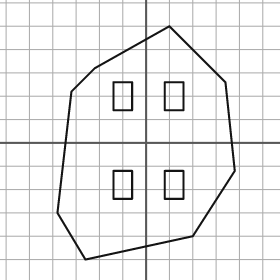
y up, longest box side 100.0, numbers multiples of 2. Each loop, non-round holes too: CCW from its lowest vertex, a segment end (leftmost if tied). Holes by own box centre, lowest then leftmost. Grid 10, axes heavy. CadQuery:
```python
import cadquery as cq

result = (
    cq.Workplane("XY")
    .moveTo(-26.0, -50.0)
    .lineTo(20.0, -40.0)
    .lineTo(38.0, -12.0)
    .lineTo(34.0, 26.0)
    .lineTo(10.0, 50.0)
    .lineTo(-22.0, 32.0)
    .lineTo(-32.0, 22.0)
    .lineTo(-38.0, -30.0)
    .close()
    .moveTo(-14.0, -24.0)
    .lineTo(-6.0, -24.0)
    .lineTo(-6.0, -12.0)
    .lineTo(-14.0, -12.0)
    .close()
    .moveTo(8.0, -24.0)
    .lineTo(16.0, -24.0)
    .lineTo(16.0, -12.0)
    .lineTo(8.0, -12.0)
    .close()
    .moveTo(-14.0, 14.0)
    .lineTo(-6.0, 14.0)
    .lineTo(-6.0, 26.0)
    .lineTo(-14.0, 26.0)
    .close()
    .moveTo(8.0, 14.0)
    .lineTo(16.0, 14.0)
    .lineTo(16.0, 26.0)
    .lineTo(8.0, 26.0)
    .close()
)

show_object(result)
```